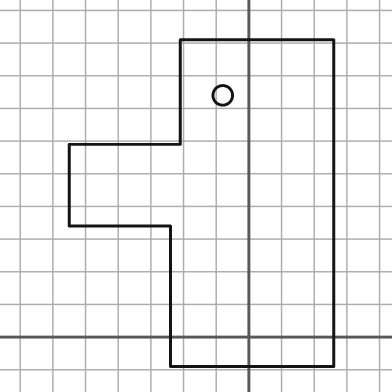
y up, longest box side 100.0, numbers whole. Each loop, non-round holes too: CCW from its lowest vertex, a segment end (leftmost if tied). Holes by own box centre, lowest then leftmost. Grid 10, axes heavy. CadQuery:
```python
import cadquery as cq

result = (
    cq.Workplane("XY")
    .moveTo(-24.0, -9.0)
    .lineTo(26.0, -9.0)
    .lineTo(26.0, 91.0)
    .lineTo(-21.0, 91.0)
    .lineTo(-21.0, 59.0)
    .lineTo(-55.0, 59.0)
    .lineTo(-55.0, 34.0)
    .lineTo(-24.0, 34.0)
    .close()
    .moveTo(-8.0, 74.0)
    .circle(3.0)
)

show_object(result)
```